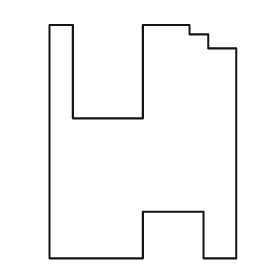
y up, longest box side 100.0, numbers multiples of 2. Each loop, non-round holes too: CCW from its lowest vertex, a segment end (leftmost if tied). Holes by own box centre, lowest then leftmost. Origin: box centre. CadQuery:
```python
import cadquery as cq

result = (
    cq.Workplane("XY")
    .moveTo(-40.0, -50.0)
    .lineTo(0.0, -50.0)
    .lineTo(0.0, -30.0)
    .lineTo(26.0, -30.0)
    .lineTo(26.0, -50.0)
    .lineTo(40.0, -50.0)
    .lineTo(40.0, 40.0)
    .lineTo(28.0, 40.0)
    .lineTo(28.0, 46.0)
    .lineTo(20.0, 46.0)
    .lineTo(20.0, 50.0)
    .lineTo(0.0, 50.0)
    .lineTo(0.0, 10.0)
    .lineTo(-30.0, 10.0)
    .lineTo(-30.0, 50.0)
    .lineTo(-40.0, 50.0)
    .close()
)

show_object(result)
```